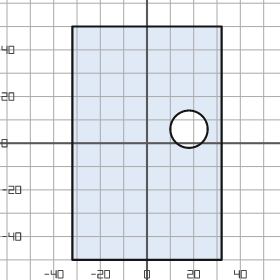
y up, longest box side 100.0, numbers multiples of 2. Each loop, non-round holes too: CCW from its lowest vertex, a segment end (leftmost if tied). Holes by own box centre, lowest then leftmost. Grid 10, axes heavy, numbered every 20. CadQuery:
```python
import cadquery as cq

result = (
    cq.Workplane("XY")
    .moveTo(-32.0, -50.0)
    .lineTo(32.0, -50.0)
    .lineTo(32.0, 50.0)
    .lineTo(-32.0, 50.0)
    .close()
    .moveTo(18.0, 6.0)
    .circle(8.0)
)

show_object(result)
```